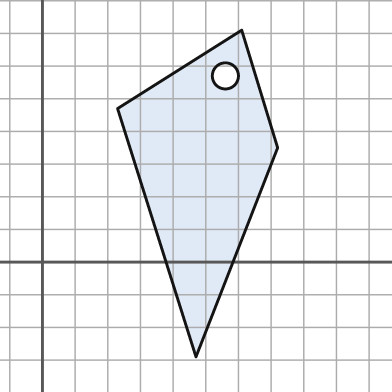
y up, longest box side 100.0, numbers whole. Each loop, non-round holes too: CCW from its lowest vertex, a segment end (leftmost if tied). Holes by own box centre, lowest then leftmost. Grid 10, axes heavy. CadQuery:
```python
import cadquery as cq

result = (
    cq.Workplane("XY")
    .moveTo(47.0, -29.0)
    .lineTo(72.0, 35.0)
    .lineTo(61.0, 71.0)
    .lineTo(23.0, 47.0)
    .close()
    .moveTo(56.0, 57.0)
    .circle(4.0)
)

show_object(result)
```